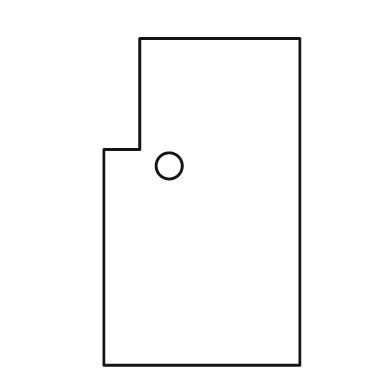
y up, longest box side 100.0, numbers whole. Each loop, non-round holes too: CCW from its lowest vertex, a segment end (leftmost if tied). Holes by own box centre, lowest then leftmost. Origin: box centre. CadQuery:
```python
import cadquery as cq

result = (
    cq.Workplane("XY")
    .moveTo(-30.0, -50.0)
    .lineTo(30.0, -50.0)
    .lineTo(30.0, 50.0)
    .lineTo(-19.0, 50.0)
    .lineTo(-19.0, 16.0)
    .lineTo(-30.0, 16.0)
    .close()
    .moveTo(-10.0, 11.0)
    .circle(4.0)
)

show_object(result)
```